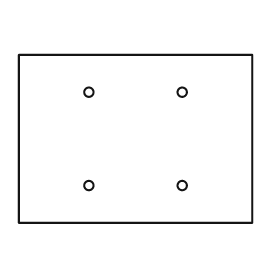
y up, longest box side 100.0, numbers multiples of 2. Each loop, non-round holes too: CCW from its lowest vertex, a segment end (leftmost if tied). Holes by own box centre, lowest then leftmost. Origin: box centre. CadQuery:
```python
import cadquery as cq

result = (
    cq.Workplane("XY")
    .moveTo(-50.0, -36.0)
    .lineTo(50.0, -36.0)
    .lineTo(50.0, 36.0)
    .lineTo(-50.0, 36.0)
    .close()
    .moveTo(-20.0, -20.0)
    .circle(2.0)
    .moveTo(20.0, -20.0)
    .circle(2.0)
    .moveTo(-20.0, 20.0)
    .circle(2.0)
    .moveTo(20.0, 20.0)
    .circle(2.0)
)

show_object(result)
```